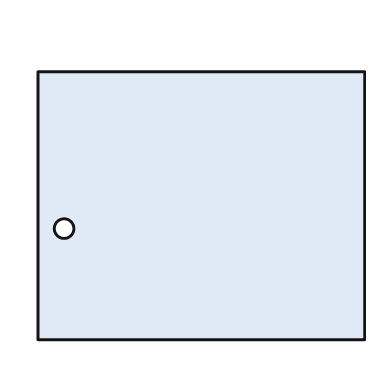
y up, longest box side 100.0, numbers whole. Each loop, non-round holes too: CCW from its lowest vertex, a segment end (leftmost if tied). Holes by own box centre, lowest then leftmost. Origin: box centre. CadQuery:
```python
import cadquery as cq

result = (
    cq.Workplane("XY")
    .moveTo(-50.0, -41.0)
    .lineTo(50.0, -41.0)
    .lineTo(50.0, 41.0)
    .lineTo(-50.0, 41.0)
    .close()
    .moveTo(-42.0, -7.0)
    .circle(3.0)
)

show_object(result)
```